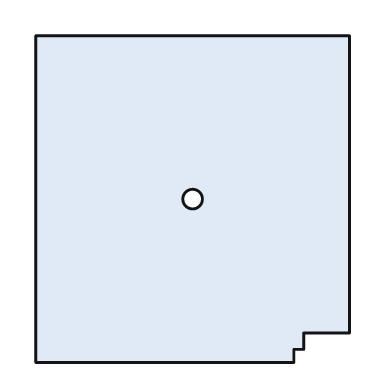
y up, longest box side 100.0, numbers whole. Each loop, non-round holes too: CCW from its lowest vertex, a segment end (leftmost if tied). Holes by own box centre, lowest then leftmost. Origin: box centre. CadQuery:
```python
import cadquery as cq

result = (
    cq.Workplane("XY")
    .moveTo(-48.0, -50.0)
    .lineTo(31.0, -50.0)
    .lineTo(31.0, -46.0)
    .lineTo(34.0, -46.0)
    .lineTo(34.0, -41.0)
    .lineTo(48.0, -41.0)
    .lineTo(48.0, 50.0)
    .lineTo(-48.0, 50.0)
    .close()
    .moveTo(0.0, 0.0)
    .circle(3.0)
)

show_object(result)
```